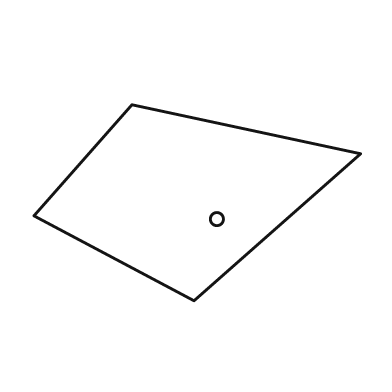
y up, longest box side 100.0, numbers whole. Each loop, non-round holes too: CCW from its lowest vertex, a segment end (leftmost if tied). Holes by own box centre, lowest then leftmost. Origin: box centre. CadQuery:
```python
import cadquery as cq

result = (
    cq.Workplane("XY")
    .moveTo(-1.0, -30.0)
    .lineTo(50.0, 15.0)
    .lineTo(-20.0, 30.0)
    .lineTo(-50.0, -4.0)
    .close()
    .moveTo(6.0, -5.0)
    .circle(2.0)
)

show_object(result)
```